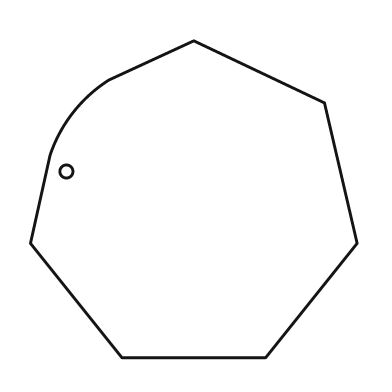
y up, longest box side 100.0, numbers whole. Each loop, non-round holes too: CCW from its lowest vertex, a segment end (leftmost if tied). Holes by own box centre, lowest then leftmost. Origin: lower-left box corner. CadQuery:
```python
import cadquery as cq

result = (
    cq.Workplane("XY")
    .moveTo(28.0, 0.0)
    .lineTo(72.0, 0.0)
    .lineTo(100.0, 35.0)
    .lineTo(90.0, 78.0)
    .lineTo(50.0, 97.0)
    .lineTo(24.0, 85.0)
    .threePointArc((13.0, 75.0), (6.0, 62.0))
    .lineTo(0.0, 35.0)
    .close()
    .moveTo(11.0, 57.0)
    .circle(2.0)
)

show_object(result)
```